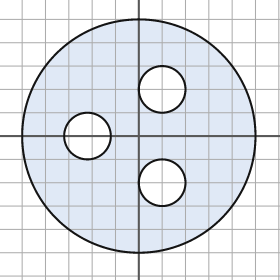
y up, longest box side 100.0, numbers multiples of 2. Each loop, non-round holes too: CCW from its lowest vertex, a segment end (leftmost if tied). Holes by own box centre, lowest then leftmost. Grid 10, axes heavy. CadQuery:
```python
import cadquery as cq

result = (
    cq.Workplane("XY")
    .moveTo(0.0, 0.0)
    .circle(50.0)
    .moveTo(10.0, -20.0)
    .circle(10.0)
    .moveTo(-22.0, 0.0)
    .circle(10.0)
    .moveTo(10.0, 20.0)
    .circle(10.0)
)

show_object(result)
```